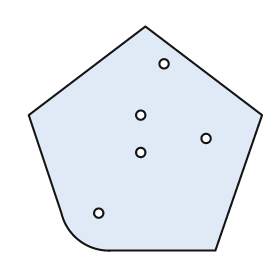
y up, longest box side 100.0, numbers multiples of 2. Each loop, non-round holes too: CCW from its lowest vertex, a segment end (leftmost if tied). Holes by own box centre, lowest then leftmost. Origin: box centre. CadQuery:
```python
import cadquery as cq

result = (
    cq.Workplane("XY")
    .moveTo(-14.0, -48.0)
    .lineTo(30.0, -48.0)
    .lineTo(50.0, 10.0)
    .lineTo(0.0, 48.0)
    .lineTo(-50.0, 10.0)
    .lineTo(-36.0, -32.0)
    .threePointArc((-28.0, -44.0), (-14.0, -48.0))
    .close()
    .moveTo(-20.0, -32.0)
    .circle(2.0)
    .moveTo(-2.0, -6.0)
    .circle(2.0)
    .moveTo(26.0, 0.0)
    .circle(2.0)
    .moveTo(-2.0, 10.0)
    .circle(2.0)
    .moveTo(8.0, 32.0)
    .circle(2.0)
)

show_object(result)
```